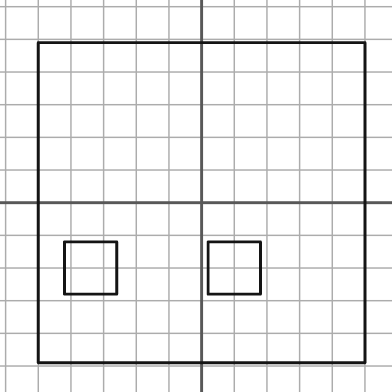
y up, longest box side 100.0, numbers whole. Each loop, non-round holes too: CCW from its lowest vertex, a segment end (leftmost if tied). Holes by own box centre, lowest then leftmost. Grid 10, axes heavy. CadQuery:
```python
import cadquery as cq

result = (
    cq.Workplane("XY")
    .moveTo(-50.0, -49.0)
    .lineTo(50.0, -49.0)
    .lineTo(50.0, 49.0)
    .lineTo(-50.0, 49.0)
    .close()
    .moveTo(-42.0, -28.0)
    .lineTo(-26.0, -28.0)
    .lineTo(-26.0, -12.0)
    .lineTo(-42.0, -12.0)
    .close()
    .moveTo(2.0, -28.0)
    .lineTo(18.0, -28.0)
    .lineTo(18.0, -12.0)
    .lineTo(2.0, -12.0)
    .close()
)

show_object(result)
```